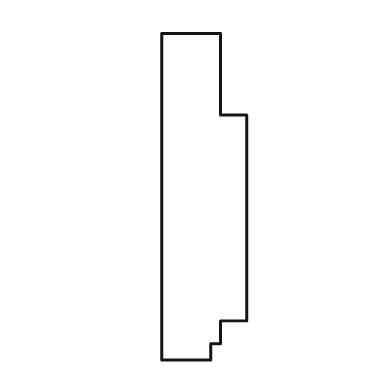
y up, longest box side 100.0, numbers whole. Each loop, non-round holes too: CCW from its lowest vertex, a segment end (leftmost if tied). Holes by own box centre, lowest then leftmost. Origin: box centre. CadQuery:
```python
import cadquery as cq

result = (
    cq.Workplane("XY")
    .moveTo(-13.0, -50.0)
    .lineTo(2.0, -50.0)
    .lineTo(2.0, -45.0)
    .lineTo(5.0, -45.0)
    .lineTo(5.0, -38.0)
    .lineTo(13.0, -38.0)
    .lineTo(13.0, 25.0)
    .lineTo(5.0, 25.0)
    .lineTo(5.0, 50.0)
    .lineTo(-13.0, 50.0)
    .close()
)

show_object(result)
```